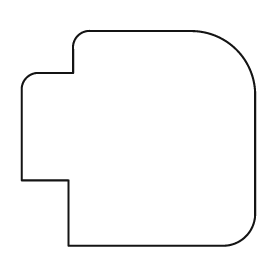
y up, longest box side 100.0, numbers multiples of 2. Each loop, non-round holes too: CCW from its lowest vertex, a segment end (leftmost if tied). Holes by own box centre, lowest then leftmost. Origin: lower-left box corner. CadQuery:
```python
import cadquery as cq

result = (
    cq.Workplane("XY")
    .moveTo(20.0, 0.0)
    .lineTo(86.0, 0.0)
    .threePointArc((96.0, 4.0), (100.0, 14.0))
    .lineTo(100.0, 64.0)
    .threePointArc((92.0, 84.0), (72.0, 92.0))
    .lineTo(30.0, 92.0)
    .threePointArc((24.0, 90.0), (22.0, 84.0))
    .lineTo(22.0, 74.0)
    .lineTo(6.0, 74.0)
    .threePointArc((2.0, 72.0), (0.0, 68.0))
    .lineTo(0.0, 28.0)
    .lineTo(20.0, 28.0)
    .close()
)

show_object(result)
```